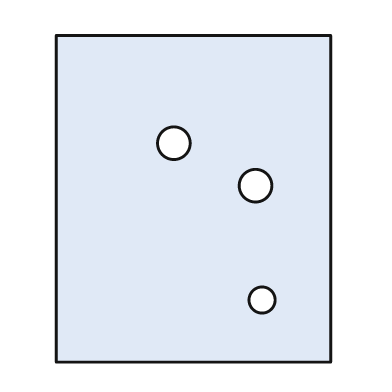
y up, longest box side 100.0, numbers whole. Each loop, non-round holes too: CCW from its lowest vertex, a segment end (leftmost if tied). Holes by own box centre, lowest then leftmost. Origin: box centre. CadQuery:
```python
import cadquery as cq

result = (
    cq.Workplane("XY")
    .moveTo(-42.0, -50.0)
    .lineTo(42.0, -50.0)
    .lineTo(42.0, 50.0)
    .lineTo(-42.0, 50.0)
    .close()
    .moveTo(21.0, -31.0)
    .circle(4.0)
    .moveTo(19.0, 4.0)
    .circle(5.0)
    .moveTo(-6.0, 17.0)
    .circle(5.0)
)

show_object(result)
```